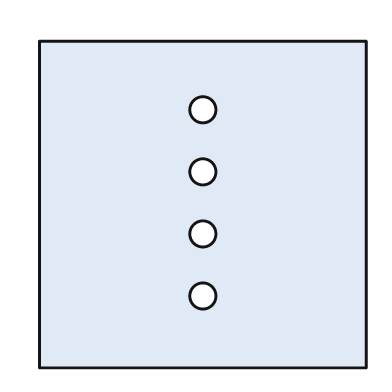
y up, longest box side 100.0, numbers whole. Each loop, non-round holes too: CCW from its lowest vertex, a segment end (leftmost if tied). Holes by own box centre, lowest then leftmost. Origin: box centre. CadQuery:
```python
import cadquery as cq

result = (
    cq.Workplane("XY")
    .moveTo(-50.0, -50.0)
    .lineTo(50.0, -50.0)
    .lineTo(50.0, 50.0)
    .lineTo(-50.0, 50.0)
    .close()
    .moveTo(0.0, -28.0)
    .circle(4.0)
    .moveTo(0.0, -9.0)
    .circle(4.0)
    .moveTo(0.0, 10.0)
    .circle(4.0)
    .moveTo(0.0, 29.0)
    .circle(4.0)
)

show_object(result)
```